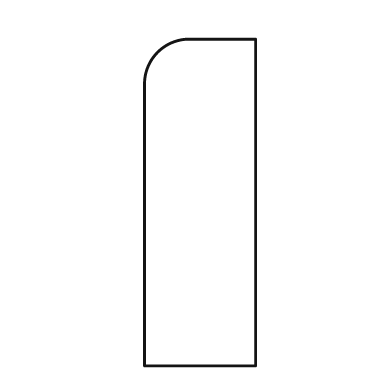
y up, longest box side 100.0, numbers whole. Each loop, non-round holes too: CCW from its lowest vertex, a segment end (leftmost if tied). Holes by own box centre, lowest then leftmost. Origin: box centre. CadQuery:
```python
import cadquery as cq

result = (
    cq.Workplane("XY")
    .moveTo(-17.0, -50.0)
    .lineTo(17.0, -50.0)
    .lineTo(17.0, 50.0)
    .lineTo(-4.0, 50.0)
    .threePointArc((-13.0, 46.0), (-17.0, 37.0))
    .close()
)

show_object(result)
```